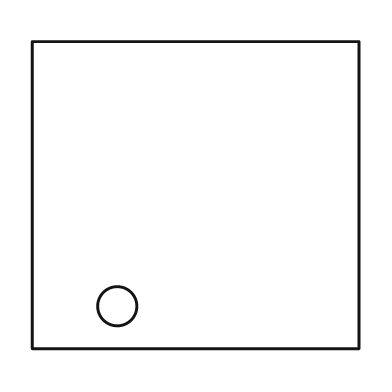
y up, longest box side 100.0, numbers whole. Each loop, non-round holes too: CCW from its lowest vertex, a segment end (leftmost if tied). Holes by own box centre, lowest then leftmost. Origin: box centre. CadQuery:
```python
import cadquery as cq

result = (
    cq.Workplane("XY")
    .moveTo(-50.0, -47.0)
    .lineTo(50.0, -47.0)
    .lineTo(50.0, 47.0)
    .lineTo(-50.0, 47.0)
    .close()
    .moveTo(-24.0, -34.0)
    .circle(6.0)
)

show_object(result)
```